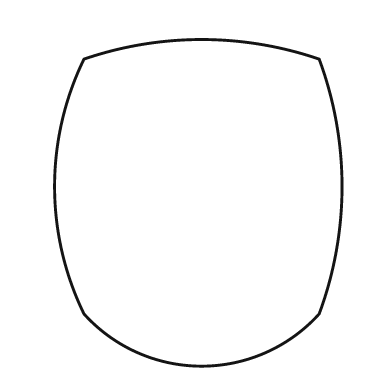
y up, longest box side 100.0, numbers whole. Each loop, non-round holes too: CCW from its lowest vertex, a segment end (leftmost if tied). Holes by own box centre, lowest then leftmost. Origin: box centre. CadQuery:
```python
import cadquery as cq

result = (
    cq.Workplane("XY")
    .moveTo(-35.0, -34.0)
    .threePointArc((1.0, -50.0), (37.0, -34.0))
    .threePointArc((44.0, 5.0), (37.0, 44.0))
    .threePointArc((1.0, 50.0), (-35.0, 44.0))
    .threePointArc((-44.0, 5.0), (-35.0, -34.0))
    .close()
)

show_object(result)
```